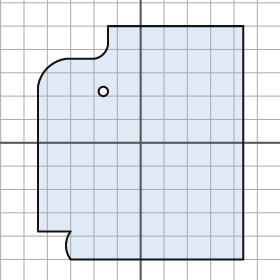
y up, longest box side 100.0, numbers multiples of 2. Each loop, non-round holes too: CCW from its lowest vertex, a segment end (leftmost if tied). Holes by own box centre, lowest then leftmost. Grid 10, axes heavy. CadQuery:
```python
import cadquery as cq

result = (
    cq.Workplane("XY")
    .moveTo(-30.0, -50.0)
    .lineTo(44.0, -50.0)
    .lineTo(44.0, 50.0)
    .lineTo(-14.0, 50.0)
    .lineTo(-14.0, 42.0)
    .threePointArc((-16.0, 38.0), (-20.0, 36.0))
    .lineTo(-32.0, 36.0)
    .threePointArc((-40.0, 32.0), (-44.0, 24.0))
    .lineTo(-44.0, -38.0)
    .lineTo(-30.0, -38.0)
    .threePointArc((-32.0, -44.0), (-30.0, -50.0))
    .close()
    .moveTo(-16.0, 22.0)
    .circle(2.0)
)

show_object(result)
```